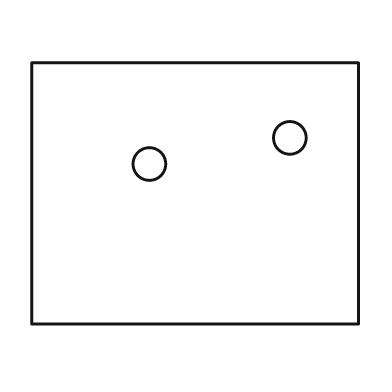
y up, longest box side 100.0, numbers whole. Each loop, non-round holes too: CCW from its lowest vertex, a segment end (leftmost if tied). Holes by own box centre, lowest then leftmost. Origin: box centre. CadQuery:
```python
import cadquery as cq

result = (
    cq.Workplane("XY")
    .moveTo(-50.0, -40.0)
    .lineTo(50.0, -40.0)
    .lineTo(50.0, 40.0)
    .lineTo(-50.0, 40.0)
    .close()
    .moveTo(-14.0, 9.0)
    .circle(5.0)
    .moveTo(29.0, 17.0)
    .circle(5.0)
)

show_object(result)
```